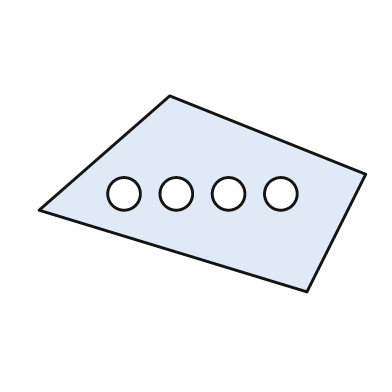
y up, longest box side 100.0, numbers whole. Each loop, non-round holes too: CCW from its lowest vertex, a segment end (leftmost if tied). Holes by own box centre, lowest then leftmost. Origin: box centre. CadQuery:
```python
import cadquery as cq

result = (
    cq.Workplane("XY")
    .moveTo(32.0, -30.0)
    .lineTo(50.0, 6.0)
    .lineTo(-10.0, 30.0)
    .lineTo(-50.0, -5.0)
    .close()
    .moveTo(-24.0, 0.0)
    .circle(5.0)
    .moveTo(-8.0, 0.0)
    .circle(5.0)
    .moveTo(8.0, 0.0)
    .circle(5.0)
    .moveTo(24.0, 0.0)
    .circle(5.0)
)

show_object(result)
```